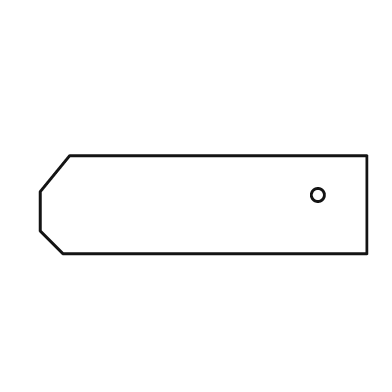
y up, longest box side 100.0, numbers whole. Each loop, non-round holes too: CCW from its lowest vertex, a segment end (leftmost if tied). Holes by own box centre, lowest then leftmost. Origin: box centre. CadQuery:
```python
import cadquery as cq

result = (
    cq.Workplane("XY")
    .moveTo(-43.0, -15.0)
    .lineTo(50.0, -15.0)
    .lineTo(50.0, 15.0)
    .lineTo(-41.0, 15.0)
    .lineTo(-50.0, 4.0)
    .lineTo(-50.0, -8.0)
    .close()
    .moveTo(35.0, 3.0)
    .circle(2.0)
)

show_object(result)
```